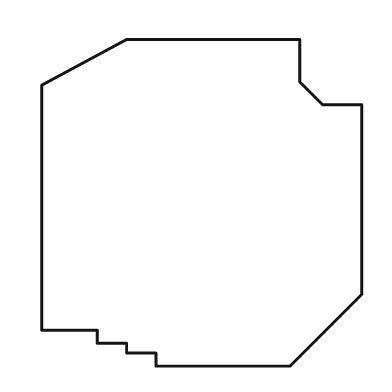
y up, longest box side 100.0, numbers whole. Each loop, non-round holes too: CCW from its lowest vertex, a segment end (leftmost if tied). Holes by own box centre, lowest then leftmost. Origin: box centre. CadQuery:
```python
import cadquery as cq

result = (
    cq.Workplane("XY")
    .moveTo(-14.0, -50.0)
    .lineTo(27.0, -50.0)
    .lineTo(49.0, -28.0)
    .lineTo(49.0, 30.0)
    .lineTo(37.0, 30.0)
    .lineTo(30.0, 37.0)
    .lineTo(30.0, 50.0)
    .lineTo(-23.0, 50.0)
    .lineTo(-49.0, 36.0)
    .lineTo(-49.0, -39.0)
    .lineTo(-32.0, -39.0)
    .lineTo(-32.0, -43.0)
    .lineTo(-23.0, -43.0)
    .lineTo(-23.0, -46.0)
    .lineTo(-14.0, -46.0)
    .close()
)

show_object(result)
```